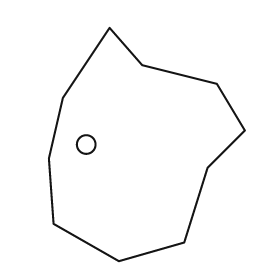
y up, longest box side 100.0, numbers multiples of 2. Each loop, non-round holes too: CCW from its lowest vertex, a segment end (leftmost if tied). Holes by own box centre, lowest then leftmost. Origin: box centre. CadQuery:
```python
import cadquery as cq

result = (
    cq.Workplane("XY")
    .moveTo(-12.0, -50.0)
    .lineTo(16.0, -42.0)
    .lineTo(26.0, -10.0)
    .lineTo(42.0, 6.0)
    .lineTo(30.0, 26.0)
    .lineTo(-2.0, 34.0)
    .lineTo(-16.0, 50.0)
    .lineTo(-36.0, 20.0)
    .lineTo(-42.0, -6.0)
    .lineTo(-40.0, -34.0)
    .close()
    .moveTo(-26.0, 0.0)
    .circle(4.0)
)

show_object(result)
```